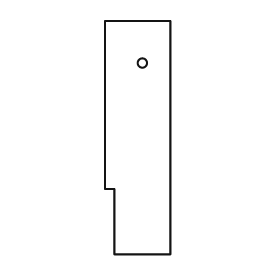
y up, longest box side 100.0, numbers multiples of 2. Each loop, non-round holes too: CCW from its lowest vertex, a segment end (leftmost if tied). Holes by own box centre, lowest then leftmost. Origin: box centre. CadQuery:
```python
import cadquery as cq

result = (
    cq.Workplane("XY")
    .moveTo(-10.0, -50.0)
    .lineTo(14.0, -50.0)
    .lineTo(14.0, 50.0)
    .lineTo(-14.0, 50.0)
    .lineTo(-14.0, -22.0)
    .lineTo(-10.0, -22.0)
    .close()
    .moveTo(2.0, 32.0)
    .circle(2.0)
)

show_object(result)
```